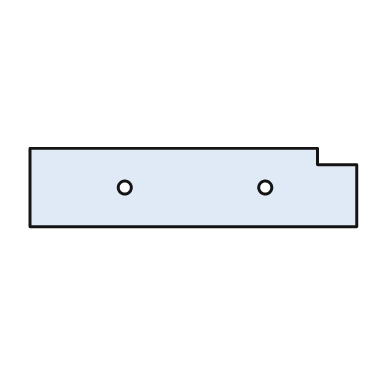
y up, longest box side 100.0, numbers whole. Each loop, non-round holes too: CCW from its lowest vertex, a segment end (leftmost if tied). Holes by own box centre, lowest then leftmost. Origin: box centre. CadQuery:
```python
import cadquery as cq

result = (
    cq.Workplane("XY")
    .moveTo(-50.0, -12.0)
    .lineTo(50.0, -12.0)
    .lineTo(50.0, 7.0)
    .lineTo(38.0, 7.0)
    .lineTo(38.0, 12.0)
    .lineTo(-50.0, 12.0)
    .close()
    .moveTo(-21.0, 0.0)
    .circle(2.0)
    .moveTo(22.0, 0.0)
    .circle(2.0)
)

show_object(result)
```